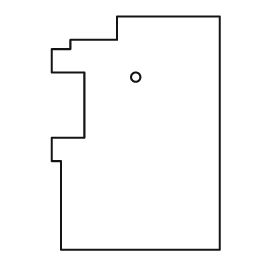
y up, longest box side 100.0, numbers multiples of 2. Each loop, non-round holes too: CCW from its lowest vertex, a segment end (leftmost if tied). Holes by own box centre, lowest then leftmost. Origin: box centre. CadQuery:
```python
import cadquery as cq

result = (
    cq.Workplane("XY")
    .moveTo(-32.0, -50.0)
    .lineTo(36.0, -50.0)
    .lineTo(36.0, 50.0)
    .lineTo(-8.0, 50.0)
    .lineTo(-8.0, 40.0)
    .lineTo(-28.0, 40.0)
    .lineTo(-28.0, 36.0)
    .lineTo(-36.0, 36.0)
    .lineTo(-36.0, 26.0)
    .lineTo(-22.0, 26.0)
    .lineTo(-22.0, -2.0)
    .lineTo(-36.0, -2.0)
    .lineTo(-36.0, -12.0)
    .lineTo(-32.0, -12.0)
    .close()
    .moveTo(0.0, 24.0)
    .circle(2.0)
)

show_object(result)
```